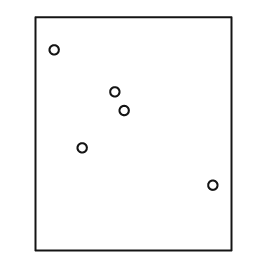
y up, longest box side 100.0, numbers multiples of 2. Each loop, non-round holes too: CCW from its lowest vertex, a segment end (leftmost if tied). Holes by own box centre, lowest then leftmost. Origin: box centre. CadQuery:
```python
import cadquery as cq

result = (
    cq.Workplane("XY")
    .moveTo(-42.0, -50.0)
    .lineTo(42.0, -50.0)
    .lineTo(42.0, 50.0)
    .lineTo(-42.0, 50.0)
    .close()
    .moveTo(34.0, -22.0)
    .circle(2.0)
    .moveTo(-22.0, -6.0)
    .circle(2.0)
    .moveTo(-4.0, 10.0)
    .circle(2.0)
    .moveTo(-8.0, 18.0)
    .circle(2.0)
    .moveTo(-34.0, 36.0)
    .circle(2.0)
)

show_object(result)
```